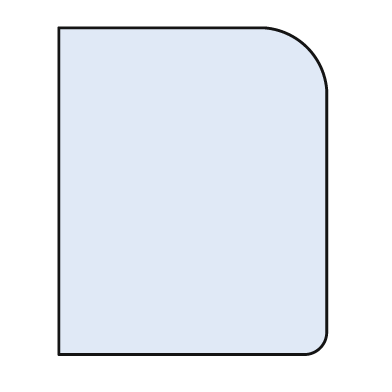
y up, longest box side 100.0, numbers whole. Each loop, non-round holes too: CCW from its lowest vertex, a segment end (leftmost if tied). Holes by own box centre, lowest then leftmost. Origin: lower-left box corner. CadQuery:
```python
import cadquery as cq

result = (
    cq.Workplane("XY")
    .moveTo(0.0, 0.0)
    .lineTo(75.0, 0.0)
    .threePointArc((80.0, 2.0), (82.0, 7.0))
    .lineTo(82.0, 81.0)
    .threePointArc((76.0, 94.0), (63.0, 100.0))
    .lineTo(0.0, 100.0)
    .close()
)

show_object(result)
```